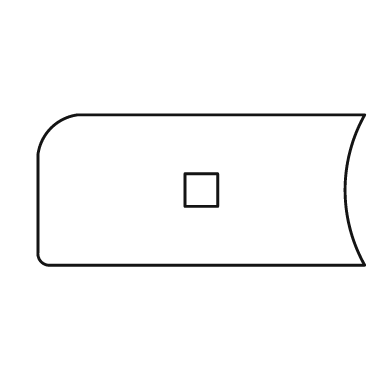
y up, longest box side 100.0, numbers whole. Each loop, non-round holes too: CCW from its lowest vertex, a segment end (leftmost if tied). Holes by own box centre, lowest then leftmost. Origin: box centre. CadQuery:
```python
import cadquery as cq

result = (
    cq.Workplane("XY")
    .moveTo(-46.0, -23.0)
    .lineTo(50.0, -23.0)
    .threePointArc((44.0, 0.0), (50.0, 23.0))
    .lineTo(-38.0, 23.0)
    .threePointArc((-46.0, 19.0), (-50.0, 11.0))
    .lineTo(-50.0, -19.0)
    .threePointArc((-49.0, -22.0), (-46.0, -23.0))
    .close()
    .moveTo(-5.0, -5.0)
    .lineTo(5.0, -5.0)
    .lineTo(5.0, 5.0)
    .lineTo(-5.0, 5.0)
    .close()
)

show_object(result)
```